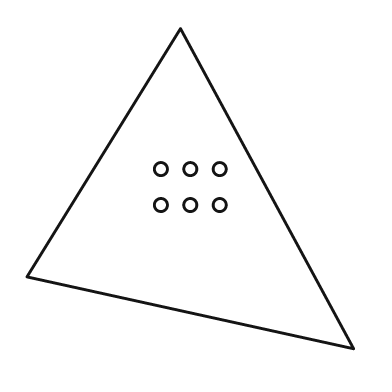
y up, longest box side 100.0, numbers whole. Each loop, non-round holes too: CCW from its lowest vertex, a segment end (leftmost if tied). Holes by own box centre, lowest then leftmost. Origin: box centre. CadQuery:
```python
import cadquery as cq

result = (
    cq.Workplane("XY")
    .moveTo(50.0, -49.0)
    .lineTo(-3.0, 49.0)
    .lineTo(-50.0, -27.0)
    .close()
    .moveTo(-9.0, -5.0)
    .circle(2.0)
    .moveTo(0.0, -5.0)
    .circle(2.0)
    .moveTo(9.0, -5.0)
    .circle(2.0)
    .moveTo(-9.0, 6.0)
    .circle(2.0)
    .moveTo(0.0, 6.0)
    .circle(2.0)
    .moveTo(9.0, 6.0)
    .circle(2.0)
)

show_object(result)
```